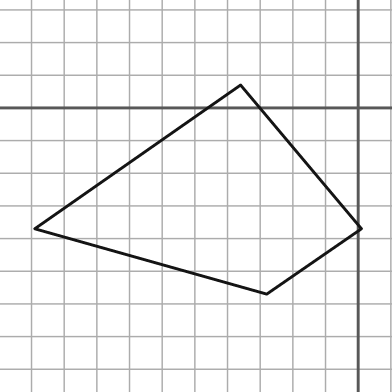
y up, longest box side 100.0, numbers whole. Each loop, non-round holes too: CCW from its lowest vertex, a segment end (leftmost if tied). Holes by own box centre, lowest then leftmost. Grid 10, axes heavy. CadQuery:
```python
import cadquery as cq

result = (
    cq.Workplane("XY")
    .moveTo(-28.0, -57.0)
    .lineTo(1.0, -37.0)
    .lineTo(-36.0, 7.0)
    .lineTo(-99.0, -37.0)
    .close()
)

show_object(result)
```